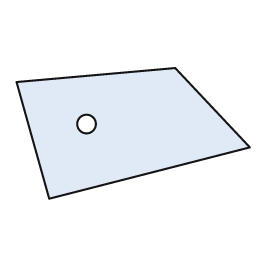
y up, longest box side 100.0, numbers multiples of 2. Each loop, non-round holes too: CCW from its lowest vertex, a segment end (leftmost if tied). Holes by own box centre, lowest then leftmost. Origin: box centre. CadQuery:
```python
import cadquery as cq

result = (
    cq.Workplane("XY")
    .moveTo(-36.0, -28.0)
    .lineTo(50.0, -6.0)
    .lineTo(18.0, 28.0)
    .lineTo(-50.0, 22.0)
    .close()
    .moveTo(-20.0, 4.0)
    .circle(4.0)
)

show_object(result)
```